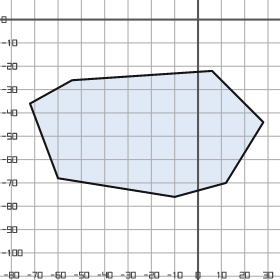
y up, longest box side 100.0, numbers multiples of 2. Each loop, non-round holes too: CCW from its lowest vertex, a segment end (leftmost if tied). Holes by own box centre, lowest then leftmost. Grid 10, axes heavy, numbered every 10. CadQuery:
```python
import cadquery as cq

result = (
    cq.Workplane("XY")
    .moveTo(-10.0, -76.0)
    .lineTo(12.0, -70.0)
    .lineTo(28.0, -44.0)
    .lineTo(6.0, -22.0)
    .lineTo(-54.0, -26.0)
    .lineTo(-72.0, -36.0)
    .lineTo(-60.0, -68.0)
    .close()
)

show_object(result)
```